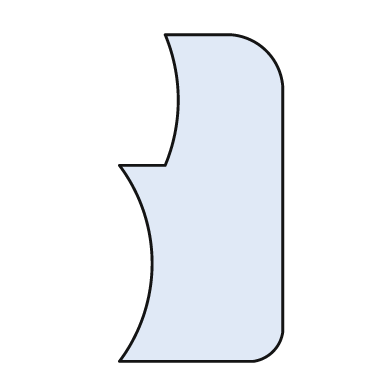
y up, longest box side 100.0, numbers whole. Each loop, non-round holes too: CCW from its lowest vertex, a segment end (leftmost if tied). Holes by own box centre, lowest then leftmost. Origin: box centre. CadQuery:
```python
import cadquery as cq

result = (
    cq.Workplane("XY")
    .moveTo(-25.0, -50.0)
    .lineTo(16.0, -50.0)
    .threePointArc((22.0, -47.0), (25.0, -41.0))
    .lineTo(25.0, 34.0)
    .threePointArc((20.0, 45.0), (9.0, 50.0))
    .lineTo(-11.0, 50.0)
    .threePointArc((-7.0, 30.0), (-11.0, 10.0))
    .lineTo(-25.0, 10.0)
    .threePointArc((-15.0, -20.0), (-25.0, -50.0))
    .close()
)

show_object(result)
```